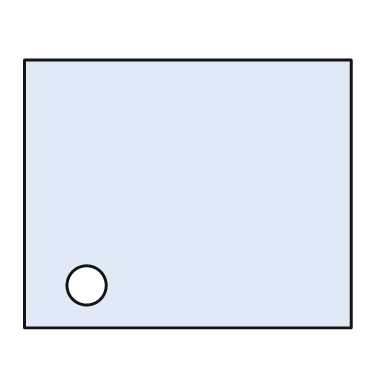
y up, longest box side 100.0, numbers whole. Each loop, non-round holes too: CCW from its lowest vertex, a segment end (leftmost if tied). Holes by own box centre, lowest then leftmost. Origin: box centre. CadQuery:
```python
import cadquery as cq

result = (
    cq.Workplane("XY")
    .moveTo(-50.0, -41.0)
    .lineTo(50.0, -41.0)
    .lineTo(50.0, 41.0)
    .lineTo(-50.0, 41.0)
    .close()
    .moveTo(-31.0, -28.0)
    .circle(6.0)
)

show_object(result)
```